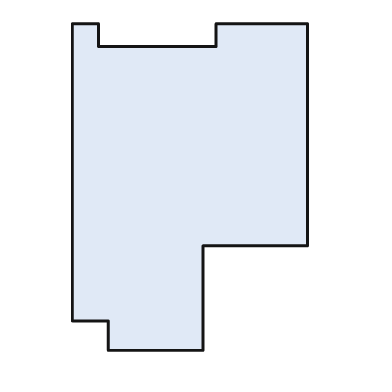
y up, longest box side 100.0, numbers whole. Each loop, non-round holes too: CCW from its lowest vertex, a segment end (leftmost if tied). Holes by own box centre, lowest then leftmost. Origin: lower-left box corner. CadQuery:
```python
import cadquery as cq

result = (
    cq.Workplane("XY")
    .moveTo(11.0, 0.0)
    .lineTo(40.0, 0.0)
    .lineTo(40.0, 32.0)
    .lineTo(72.0, 32.0)
    .lineTo(72.0, 100.0)
    .lineTo(44.0, 100.0)
    .lineTo(44.0, 93.0)
    .lineTo(8.0, 93.0)
    .lineTo(8.0, 100.0)
    .lineTo(0.0, 100.0)
    .lineTo(0.0, 9.0)
    .lineTo(11.0, 9.0)
    .close()
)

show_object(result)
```